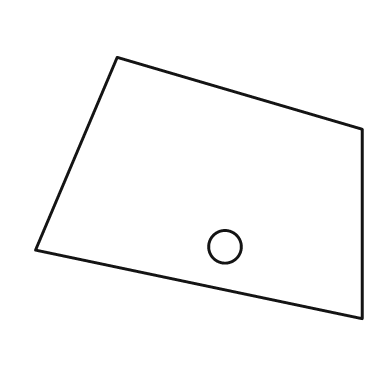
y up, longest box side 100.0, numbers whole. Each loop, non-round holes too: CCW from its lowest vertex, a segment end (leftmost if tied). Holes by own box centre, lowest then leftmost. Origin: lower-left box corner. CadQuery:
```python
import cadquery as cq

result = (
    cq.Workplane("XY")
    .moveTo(100.0, 0.0)
    .lineTo(100.0, 58.0)
    .lineTo(25.0, 80.0)
    .lineTo(0.0, 21.0)
    .close()
    .moveTo(58.0, 22.0)
    .circle(5.0)
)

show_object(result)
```